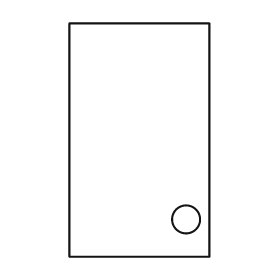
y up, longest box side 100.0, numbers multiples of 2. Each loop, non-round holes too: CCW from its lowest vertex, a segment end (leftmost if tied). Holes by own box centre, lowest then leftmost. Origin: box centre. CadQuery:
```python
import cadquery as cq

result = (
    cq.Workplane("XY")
    .moveTo(-30.0, -50.0)
    .lineTo(30.0, -50.0)
    .lineTo(30.0, 50.0)
    .lineTo(-30.0, 50.0)
    .close()
    .moveTo(20.0, -34.0)
    .circle(6.0)
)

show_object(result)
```